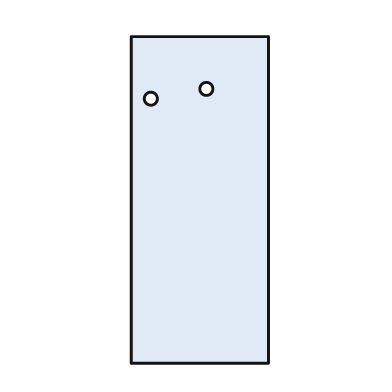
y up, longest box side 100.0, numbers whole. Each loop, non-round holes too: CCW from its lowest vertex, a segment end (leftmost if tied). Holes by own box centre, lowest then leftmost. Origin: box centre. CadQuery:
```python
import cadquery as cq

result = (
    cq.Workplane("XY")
    .moveTo(-21.0, -50.0)
    .lineTo(21.0, -50.0)
    .lineTo(21.0, 50.0)
    .lineTo(-21.0, 50.0)
    .close()
    .moveTo(-15.0, 31.0)
    .circle(2.0)
    .moveTo(2.0, 34.0)
    .circle(2.0)
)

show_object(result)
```